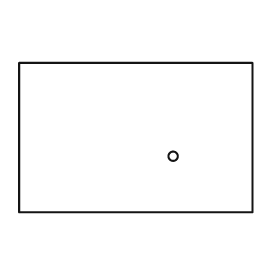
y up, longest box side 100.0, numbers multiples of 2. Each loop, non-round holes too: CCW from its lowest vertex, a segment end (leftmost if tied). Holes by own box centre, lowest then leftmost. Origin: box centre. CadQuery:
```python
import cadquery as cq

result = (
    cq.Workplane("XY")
    .moveTo(-50.0, -32.0)
    .lineTo(50.0, -32.0)
    .lineTo(50.0, 32.0)
    .lineTo(-50.0, 32.0)
    .close()
    .moveTo(16.0, -8.0)
    .circle(2.0)
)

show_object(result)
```